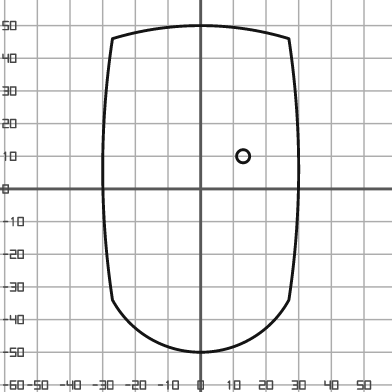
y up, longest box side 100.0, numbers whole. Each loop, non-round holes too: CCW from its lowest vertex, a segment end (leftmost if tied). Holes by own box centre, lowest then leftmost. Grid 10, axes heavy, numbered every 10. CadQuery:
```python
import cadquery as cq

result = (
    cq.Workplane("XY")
    .moveTo(-27.0, -34.0)
    .threePointArc((0.0, -50.0), (27.0, -34.0))
    .threePointArc((30.0, 6.0), (27.0, 46.0))
    .threePointArc((0.0, 50.0), (-27.0, 46.0))
    .threePointArc((-30.0, 6.0), (-27.0, -34.0))
    .close()
    .moveTo(13.0, 10.0)
    .circle(2.0)
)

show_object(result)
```